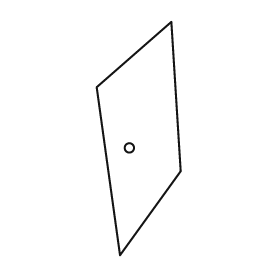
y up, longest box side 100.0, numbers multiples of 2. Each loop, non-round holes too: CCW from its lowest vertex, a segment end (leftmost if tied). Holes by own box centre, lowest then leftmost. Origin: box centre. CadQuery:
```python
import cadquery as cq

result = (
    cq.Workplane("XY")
    .moveTo(-8.0, -50.0)
    .lineTo(18.0, -14.0)
    .lineTo(14.0, 50.0)
    .lineTo(-18.0, 22.0)
    .close()
    .moveTo(-4.0, -4.0)
    .circle(2.0)
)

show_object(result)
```